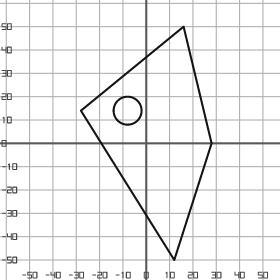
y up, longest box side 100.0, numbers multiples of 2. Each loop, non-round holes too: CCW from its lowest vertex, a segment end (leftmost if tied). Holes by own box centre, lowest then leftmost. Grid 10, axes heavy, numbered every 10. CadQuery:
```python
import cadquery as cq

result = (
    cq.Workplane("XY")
    .moveTo(12.0, -50.0)
    .lineTo(28.0, 0.0)
    .lineTo(16.0, 50.0)
    .lineTo(-28.0, 14.0)
    .close()
    .moveTo(-8.0, 14.0)
    .circle(6.0)
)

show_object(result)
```